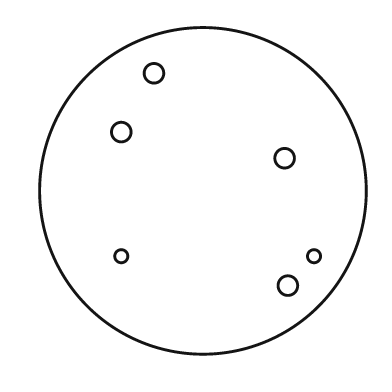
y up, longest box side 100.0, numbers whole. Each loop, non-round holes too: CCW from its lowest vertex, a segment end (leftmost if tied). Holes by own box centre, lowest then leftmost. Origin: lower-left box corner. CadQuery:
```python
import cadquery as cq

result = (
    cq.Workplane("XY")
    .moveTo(50.0, 50.0)
    .circle(50.0)
    .moveTo(76.0, 21.0)
    .circle(3.0)
    .moveTo(25.0, 30.0)
    .circle(2.0)
    .moveTo(84.0, 30.0)
    .circle(2.0)
    .moveTo(75.0, 60.0)
    .circle(3.0)
    .moveTo(25.0, 68.0)
    .circle(3.0)
    .moveTo(35.0, 86.0)
    .circle(3.0)
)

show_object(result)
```